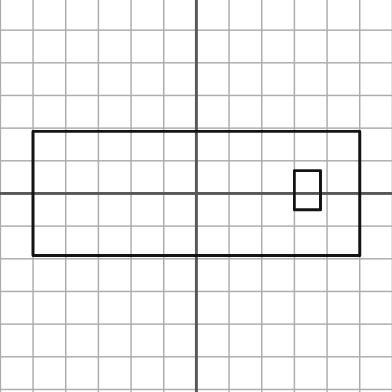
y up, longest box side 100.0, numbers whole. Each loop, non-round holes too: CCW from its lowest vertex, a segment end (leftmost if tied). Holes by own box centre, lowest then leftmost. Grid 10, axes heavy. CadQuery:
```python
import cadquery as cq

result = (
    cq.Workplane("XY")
    .moveTo(-50.0, -19.0)
    .lineTo(50.0, -19.0)
    .lineTo(50.0, 19.0)
    .lineTo(-50.0, 19.0)
    .close()
    .moveTo(30.0, -5.0)
    .lineTo(38.0, -5.0)
    .lineTo(38.0, 7.0)
    .lineTo(30.0, 7.0)
    .close()
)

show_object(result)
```